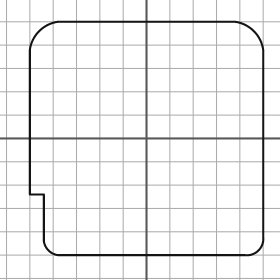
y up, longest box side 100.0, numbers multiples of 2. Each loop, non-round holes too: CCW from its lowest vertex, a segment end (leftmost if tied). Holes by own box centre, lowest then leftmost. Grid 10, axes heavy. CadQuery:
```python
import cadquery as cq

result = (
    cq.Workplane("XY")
    .moveTo(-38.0, -50.0)
    .lineTo(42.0, -50.0)
    .threePointArc((48.0, -48.0), (50.0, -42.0))
    .lineTo(50.0, 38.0)
    .threePointArc((46.0, 46.0), (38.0, 50.0))
    .lineTo(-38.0, 50.0)
    .threePointArc((-46.0, 46.0), (-50.0, 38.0))
    .lineTo(-50.0, -24.0)
    .lineTo(-44.0, -24.0)
    .lineTo(-44.0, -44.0)
    .threePointArc((-42.0, -48.0), (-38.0, -50.0))
    .close()
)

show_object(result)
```